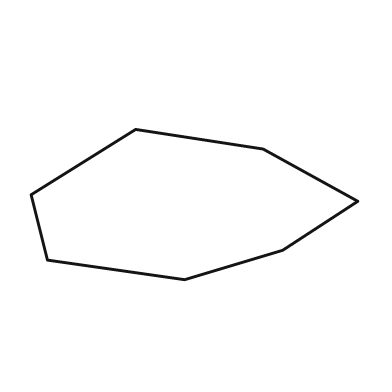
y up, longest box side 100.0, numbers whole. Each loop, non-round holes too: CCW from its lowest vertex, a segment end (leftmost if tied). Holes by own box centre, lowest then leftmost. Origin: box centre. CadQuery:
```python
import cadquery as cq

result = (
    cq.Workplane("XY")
    .moveTo(-3.0, -23.0)
    .lineTo(27.0, -14.0)
    .lineTo(50.0, 1.0)
    .lineTo(21.0, 17.0)
    .lineTo(-18.0, 23.0)
    .lineTo(-50.0, 3.0)
    .lineTo(-45.0, -17.0)
    .close()
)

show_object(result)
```